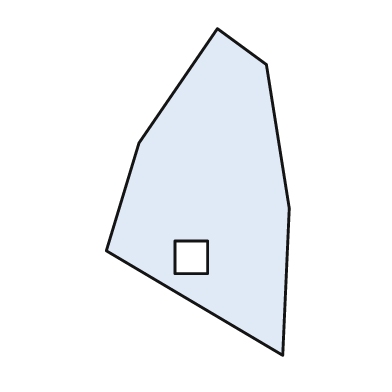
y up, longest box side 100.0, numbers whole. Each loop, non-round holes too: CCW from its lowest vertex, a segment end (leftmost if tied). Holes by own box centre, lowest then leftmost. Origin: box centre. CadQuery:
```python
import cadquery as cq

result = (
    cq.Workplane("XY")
    .moveTo(26.0, -50.0)
    .lineTo(28.0, -5.0)
    .lineTo(21.0, 39.0)
    .lineTo(6.0, 50.0)
    .lineTo(-18.0, 15.0)
    .lineTo(-28.0, -18.0)
    .close()
    .moveTo(-7.0, -25.0)
    .lineTo(3.0, -25.0)
    .lineTo(3.0, -15.0)
    .lineTo(-7.0, -15.0)
    .close()
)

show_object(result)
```